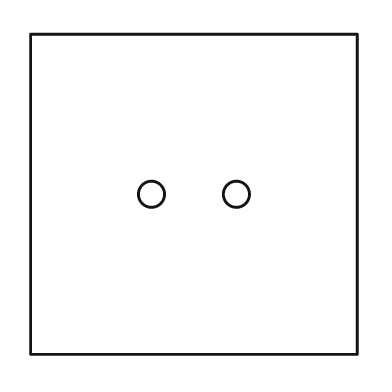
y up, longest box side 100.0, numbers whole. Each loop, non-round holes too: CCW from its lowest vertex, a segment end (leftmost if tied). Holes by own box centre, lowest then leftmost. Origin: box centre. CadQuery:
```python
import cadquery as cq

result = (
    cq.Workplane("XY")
    .moveTo(-50.0, -49.0)
    .lineTo(50.0, -49.0)
    .lineTo(50.0, 49.0)
    .lineTo(-50.0, 49.0)
    .close()
    .moveTo(-13.0, 0.0)
    .circle(4.0)
    .moveTo(13.0, 0.0)
    .circle(4.0)
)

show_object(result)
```